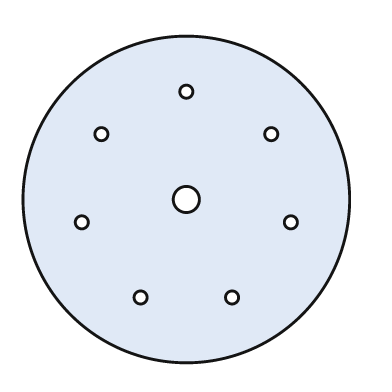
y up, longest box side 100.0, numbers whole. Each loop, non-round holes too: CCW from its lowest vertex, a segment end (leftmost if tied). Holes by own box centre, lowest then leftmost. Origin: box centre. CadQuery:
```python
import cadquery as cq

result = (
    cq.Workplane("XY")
    .moveTo(0.0, 0.0)
    .circle(50.0)
    .moveTo(-14.0, -30.0)
    .circle(2.0)
    .moveTo(14.0, -30.0)
    .circle(2.0)
    .moveTo(-32.0, -7.0)
    .circle(2.0)
    .moveTo(32.0, -7.0)
    .circle(2.0)
    .moveTo(0.0, 0.0)
    .circle(4.0)
    .moveTo(-26.0, 20.0)
    .circle(2.0)
    .moveTo(26.0, 20.0)
    .circle(2.0)
    .moveTo(0.0, 33.0)
    .circle(2.0)
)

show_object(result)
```